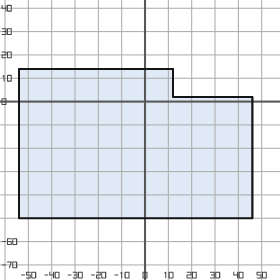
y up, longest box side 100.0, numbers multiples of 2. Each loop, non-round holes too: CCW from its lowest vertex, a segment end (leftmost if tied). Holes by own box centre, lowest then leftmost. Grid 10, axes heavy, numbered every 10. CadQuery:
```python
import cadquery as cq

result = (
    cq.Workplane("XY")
    .moveTo(-54.0, -50.0)
    .lineTo(46.0, -50.0)
    .lineTo(46.0, 2.0)
    .lineTo(12.0, 2.0)
    .lineTo(12.0, 14.0)
    .lineTo(-54.0, 14.0)
    .close()
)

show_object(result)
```